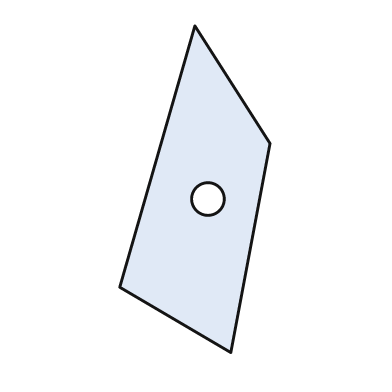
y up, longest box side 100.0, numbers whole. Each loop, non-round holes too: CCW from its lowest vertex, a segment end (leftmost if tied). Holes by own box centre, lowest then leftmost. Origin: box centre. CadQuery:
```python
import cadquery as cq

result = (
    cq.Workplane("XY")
    .moveTo(11.0, -50.0)
    .lineTo(23.0, 14.0)
    .lineTo(0.0, 50.0)
    .lineTo(-23.0, -30.0)
    .close()
    .moveTo(4.0, -3.0)
    .circle(5.0)
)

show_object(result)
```